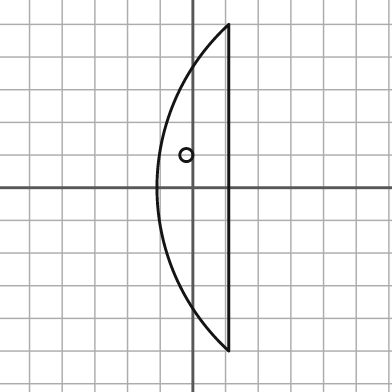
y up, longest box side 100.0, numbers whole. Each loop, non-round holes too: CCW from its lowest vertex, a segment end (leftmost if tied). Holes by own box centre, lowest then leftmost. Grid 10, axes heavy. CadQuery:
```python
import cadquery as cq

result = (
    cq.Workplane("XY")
    .moveTo(11.0, -50.0)
    .lineTo(11.0, 50.0)
    .threePointArc((-11.0, 0.0), (11.0, -50.0))
    .close()
    .moveTo(-2.0, 10.0)
    .circle(2.0)
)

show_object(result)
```